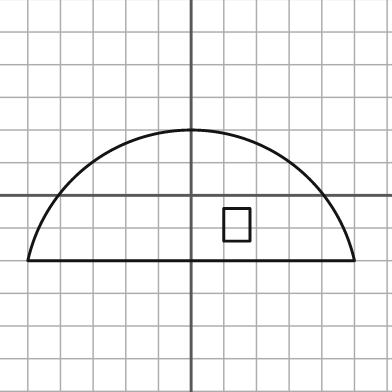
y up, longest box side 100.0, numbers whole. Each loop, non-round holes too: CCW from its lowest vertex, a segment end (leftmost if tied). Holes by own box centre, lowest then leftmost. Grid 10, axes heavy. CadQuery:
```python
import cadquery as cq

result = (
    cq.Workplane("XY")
    .moveTo(-50.0, -20.0)
    .lineTo(50.0, -20.0)
    .threePointArc((0.0, 20.0), (-50.0, -20.0))
    .close()
    .moveTo(10.0, -14.0)
    .lineTo(18.0, -14.0)
    .lineTo(18.0, -4.0)
    .lineTo(10.0, -4.0)
    .close()
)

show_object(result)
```